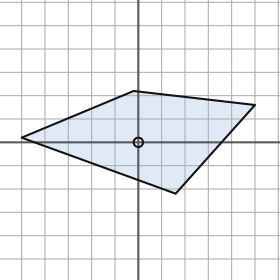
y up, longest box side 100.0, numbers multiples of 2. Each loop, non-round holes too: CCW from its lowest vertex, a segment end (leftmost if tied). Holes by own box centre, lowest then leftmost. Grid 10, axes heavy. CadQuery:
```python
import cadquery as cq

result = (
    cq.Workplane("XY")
    .moveTo(16.0, -22.0)
    .lineTo(50.0, 16.0)
    .lineTo(-2.0, 22.0)
    .lineTo(-50.0, 2.0)
    .close()
    .moveTo(0.0, 0.0)
    .circle(2.0)
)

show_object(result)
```